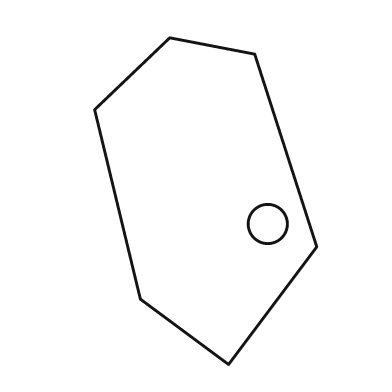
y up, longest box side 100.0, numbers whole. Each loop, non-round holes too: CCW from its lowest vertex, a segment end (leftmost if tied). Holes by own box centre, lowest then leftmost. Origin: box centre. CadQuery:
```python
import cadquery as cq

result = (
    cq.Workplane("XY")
    .moveTo(7.0, -50.0)
    .lineTo(34.0, -14.0)
    .lineTo(15.0, 45.0)
    .lineTo(-11.0, 50.0)
    .lineTo(-34.0, 28.0)
    .lineTo(-20.0, -30.0)
    .close()
    .moveTo(19.0, -7.0)
    .circle(6.0)
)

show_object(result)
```